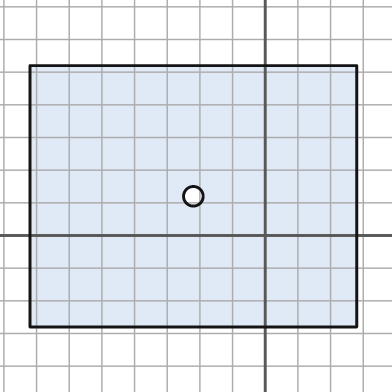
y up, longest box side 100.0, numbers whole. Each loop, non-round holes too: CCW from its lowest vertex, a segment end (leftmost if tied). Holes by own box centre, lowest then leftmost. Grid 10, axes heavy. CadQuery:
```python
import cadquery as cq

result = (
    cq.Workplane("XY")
    .moveTo(-72.0, -28.0)
    .lineTo(28.0, -28.0)
    .lineTo(28.0, 52.0)
    .lineTo(-72.0, 52.0)
    .close()
    .moveTo(-22.0, 12.0)
    .circle(3.0)
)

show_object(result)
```